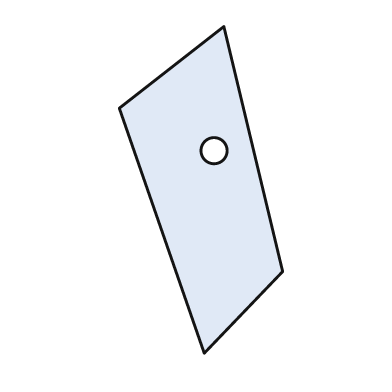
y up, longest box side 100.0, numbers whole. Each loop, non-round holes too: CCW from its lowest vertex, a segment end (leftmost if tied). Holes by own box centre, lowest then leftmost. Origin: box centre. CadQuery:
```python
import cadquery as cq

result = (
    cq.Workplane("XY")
    .moveTo(1.0, -50.0)
    .lineTo(25.0, -25.0)
    .lineTo(7.0, 50.0)
    .lineTo(-25.0, 25.0)
    .close()
    .moveTo(4.0, 12.0)
    .circle(4.0)
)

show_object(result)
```